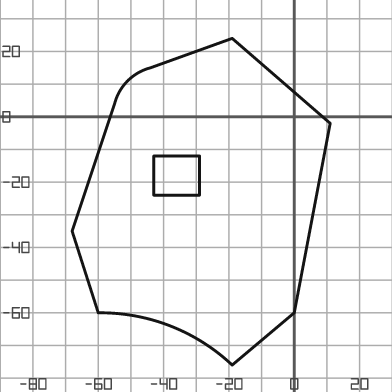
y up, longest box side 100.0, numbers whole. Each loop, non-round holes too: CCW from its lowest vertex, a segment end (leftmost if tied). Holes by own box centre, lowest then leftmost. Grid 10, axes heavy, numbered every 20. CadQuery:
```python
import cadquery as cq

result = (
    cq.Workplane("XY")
    .moveTo(-19.0, -76.0)
    .lineTo(0.0, -60.0)
    .lineTo(11.0, -2.0)
    .lineTo(-19.0, 24.0)
    .lineTo(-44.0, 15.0)
    .threePointArc((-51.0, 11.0), (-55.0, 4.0))
    .lineTo(-68.0, -35.0)
    .lineTo(-60.0, -60.0)
    .threePointArc((-38.0, -64.0), (-19.0, -76.0))
    .close()
    .moveTo(-43.0, -24.0)
    .lineTo(-29.0, -24.0)
    .lineTo(-29.0, -12.0)
    .lineTo(-43.0, -12.0)
    .close()
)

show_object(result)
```